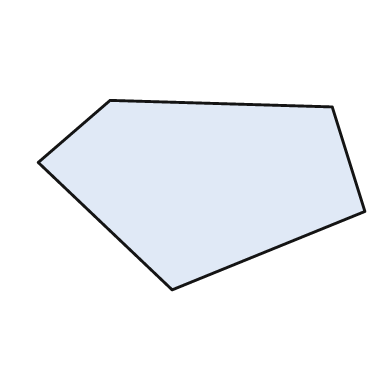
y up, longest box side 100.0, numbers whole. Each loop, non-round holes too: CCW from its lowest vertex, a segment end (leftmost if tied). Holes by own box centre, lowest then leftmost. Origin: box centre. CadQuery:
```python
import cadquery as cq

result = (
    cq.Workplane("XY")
    .moveTo(-9.0, -29.0)
    .lineTo(50.0, -5.0)
    .lineTo(40.0, 27.0)
    .lineTo(-28.0, 29.0)
    .lineTo(-50.0, 10.0)
    .close()
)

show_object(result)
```